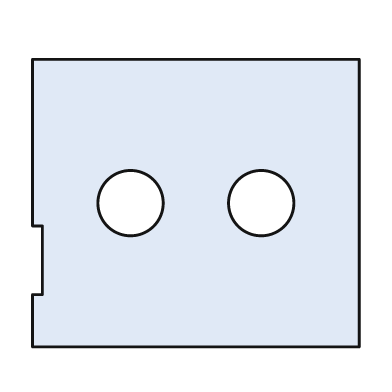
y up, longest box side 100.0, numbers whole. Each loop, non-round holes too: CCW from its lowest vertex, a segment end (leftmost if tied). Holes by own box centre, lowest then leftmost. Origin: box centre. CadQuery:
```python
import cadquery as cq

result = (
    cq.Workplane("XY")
    .moveTo(-50.0, -44.0)
    .lineTo(50.0, -44.0)
    .lineTo(50.0, 44.0)
    .lineTo(-50.0, 44.0)
    .lineTo(-50.0, -7.0)
    .lineTo(-47.0, -7.0)
    .lineTo(-47.0, -28.0)
    .lineTo(-50.0, -28.0)
    .close()
    .moveTo(-20.0, 0.0)
    .circle(10.0)
    .moveTo(20.0, 0.0)
    .circle(10.0)
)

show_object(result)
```